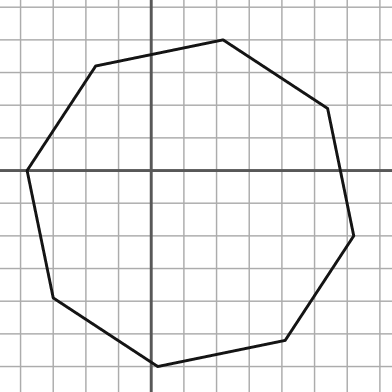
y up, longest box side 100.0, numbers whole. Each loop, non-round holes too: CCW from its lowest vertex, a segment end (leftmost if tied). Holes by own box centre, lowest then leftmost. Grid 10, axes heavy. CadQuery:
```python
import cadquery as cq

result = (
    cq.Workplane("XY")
    .moveTo(2.0, -60.0)
    .lineTo(41.0, -52.0)
    .lineTo(62.0, -20.0)
    .lineTo(54.0, 19.0)
    .lineTo(22.0, 40.0)
    .lineTo(-17.0, 32.0)
    .lineTo(-38.0, 0.0)
    .lineTo(-30.0, -39.0)
    .close()
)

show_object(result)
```